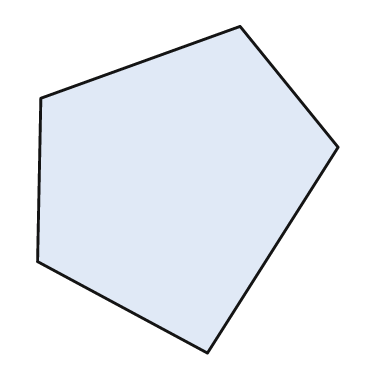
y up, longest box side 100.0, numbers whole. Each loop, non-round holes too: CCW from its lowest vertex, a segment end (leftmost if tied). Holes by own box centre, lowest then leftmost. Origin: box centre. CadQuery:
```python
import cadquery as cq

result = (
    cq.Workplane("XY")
    .moveTo(6.0, -50.0)
    .lineTo(46.0, 13.0)
    .lineTo(16.0, 50.0)
    .lineTo(-45.0, 28.0)
    .lineTo(-46.0, -22.0)
    .close()
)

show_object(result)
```